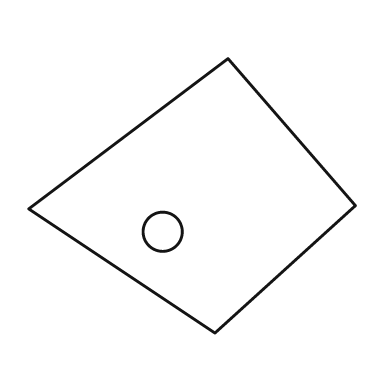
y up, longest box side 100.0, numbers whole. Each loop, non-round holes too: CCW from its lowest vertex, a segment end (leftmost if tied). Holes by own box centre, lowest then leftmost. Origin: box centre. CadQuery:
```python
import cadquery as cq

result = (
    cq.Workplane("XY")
    .moveTo(7.0, -42.0)
    .lineTo(50.0, -3.0)
    .lineTo(11.0, 42.0)
    .lineTo(-50.0, -4.0)
    .close()
    .moveTo(-9.0, -11.0)
    .circle(6.0)
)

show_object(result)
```